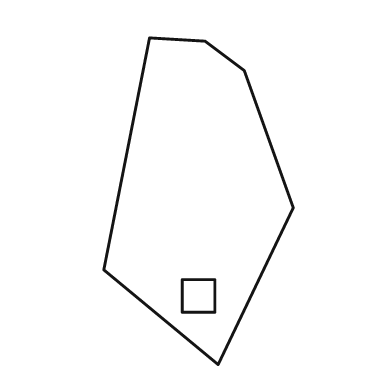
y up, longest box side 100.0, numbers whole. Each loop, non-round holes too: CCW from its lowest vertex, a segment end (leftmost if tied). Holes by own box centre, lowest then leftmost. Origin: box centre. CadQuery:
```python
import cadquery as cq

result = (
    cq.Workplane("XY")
    .moveTo(6.0, -50.0)
    .lineTo(29.0, -2.0)
    .lineTo(14.0, 40.0)
    .lineTo(2.0, 49.0)
    .lineTo(-15.0, 50.0)
    .lineTo(-29.0, -21.0)
    .close()
    .moveTo(-5.0, -34.0)
    .lineTo(5.0, -34.0)
    .lineTo(5.0, -24.0)
    .lineTo(-5.0, -24.0)
    .close()
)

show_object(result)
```